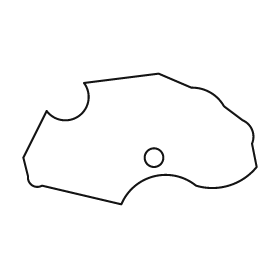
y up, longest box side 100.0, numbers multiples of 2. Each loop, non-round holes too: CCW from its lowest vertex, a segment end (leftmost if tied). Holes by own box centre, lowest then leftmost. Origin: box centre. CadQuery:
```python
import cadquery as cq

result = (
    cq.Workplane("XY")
    .moveTo(-8.0, -28.0)
    .threePointArc((6.0, -16.0), (24.0, -20.0))
    .threePointArc((38.0, -20.0), (50.0, -12.0))
    .lineTo(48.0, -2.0)
    .threePointArc((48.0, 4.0), (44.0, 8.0))
    .lineTo(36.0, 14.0)
    .threePointArc((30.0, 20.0), (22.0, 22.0))
    .lineTo(8.0, 28.0)
    .lineTo(-24.0, 24.0)
    .threePointArc((-26.0, 10.0), (-40.0, 12.0))
    .lineTo(-50.0, -8.0)
    .lineTo(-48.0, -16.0)
    .threePointArc((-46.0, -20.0), (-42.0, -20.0))
    .close()
    .moveTo(6.0, -8.0)
    .circle(4.0)
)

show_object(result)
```